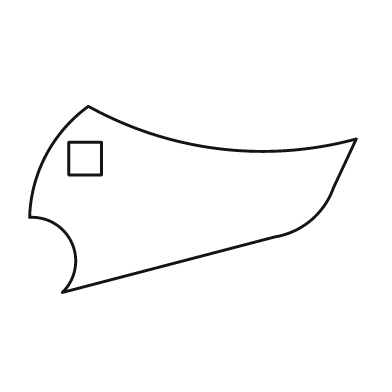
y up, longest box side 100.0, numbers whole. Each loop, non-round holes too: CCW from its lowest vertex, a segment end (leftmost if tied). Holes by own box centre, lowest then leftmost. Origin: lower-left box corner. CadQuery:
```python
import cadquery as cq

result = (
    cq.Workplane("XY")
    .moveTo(10.0, 0.0)
    .lineTo(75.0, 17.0)
    .threePointArc((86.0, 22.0), (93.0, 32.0))
    .lineTo(100.0, 47.0)
    .threePointArc((58.0, 44.0), (18.0, 57.0))
    .threePointArc((5.0, 42.0), (0.0, 23.0))
    .threePointArc((13.0, 15.0), (10.0, 0.0))
    .close()
    .moveTo(12.0, 36.0)
    .lineTo(22.0, 36.0)
    .lineTo(22.0, 46.0)
    .lineTo(12.0, 46.0)
    .close()
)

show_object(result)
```